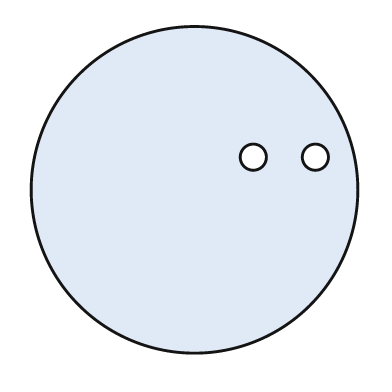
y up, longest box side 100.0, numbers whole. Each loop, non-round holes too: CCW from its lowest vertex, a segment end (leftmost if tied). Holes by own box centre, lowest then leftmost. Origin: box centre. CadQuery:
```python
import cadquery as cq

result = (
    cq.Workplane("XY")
    .moveTo(0.0, 0.0)
    .circle(50.0)
    .moveTo(18.0, 10.0)
    .circle(4.0)
    .moveTo(37.0, 10.0)
    .circle(4.0)
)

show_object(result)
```